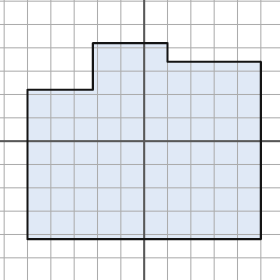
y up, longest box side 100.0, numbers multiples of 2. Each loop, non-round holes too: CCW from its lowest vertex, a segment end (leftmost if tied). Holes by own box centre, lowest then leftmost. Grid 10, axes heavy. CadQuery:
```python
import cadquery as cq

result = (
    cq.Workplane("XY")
    .moveTo(-50.0, -42.0)
    .lineTo(50.0, -42.0)
    .lineTo(50.0, 34.0)
    .lineTo(10.0, 34.0)
    .lineTo(10.0, 42.0)
    .lineTo(-22.0, 42.0)
    .lineTo(-22.0, 22.0)
    .lineTo(-50.0, 22.0)
    .close()
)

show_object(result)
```